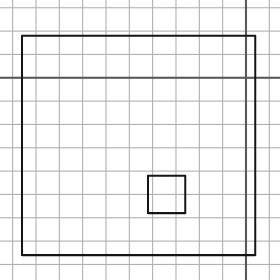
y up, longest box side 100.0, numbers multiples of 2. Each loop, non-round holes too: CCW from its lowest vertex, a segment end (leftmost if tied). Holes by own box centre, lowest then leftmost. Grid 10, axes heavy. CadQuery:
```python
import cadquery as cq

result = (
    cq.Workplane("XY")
    .moveTo(-96.0, -76.0)
    .lineTo(4.0, -76.0)
    .lineTo(4.0, 18.0)
    .lineTo(-96.0, 18.0)
    .close()
    .moveTo(-42.0, -58.0)
    .lineTo(-26.0, -58.0)
    .lineTo(-26.0, -42.0)
    .lineTo(-42.0, -42.0)
    .close()
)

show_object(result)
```